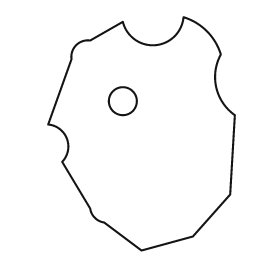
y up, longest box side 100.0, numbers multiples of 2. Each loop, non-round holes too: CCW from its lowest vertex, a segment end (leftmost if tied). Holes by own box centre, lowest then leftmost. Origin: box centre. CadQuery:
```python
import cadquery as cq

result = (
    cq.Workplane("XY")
    .moveTo(0.0, -50.0)
    .lineTo(22.0, -44.0)
    .lineTo(38.0, -26.0)
    .lineTo(40.0, 8.0)
    .threePointArc((32.0, 20.0), (34.0, 34.0))
    .threePointArc((28.0, 44.0), (18.0, 50.0))
    .threePointArc((6.0, 38.0), (-8.0, 48.0))
    .lineTo(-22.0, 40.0)
    .threePointArc((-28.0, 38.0), (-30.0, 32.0))
    .lineTo(-40.0, 4.0)
    .threePointArc((-32.0, -2.0), (-34.0, -12.0))
    .lineTo(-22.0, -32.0)
    .threePointArc((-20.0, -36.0), (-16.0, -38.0))
    .close()
    .moveTo(-8.0, 14.0)
    .circle(6.0)
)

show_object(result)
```